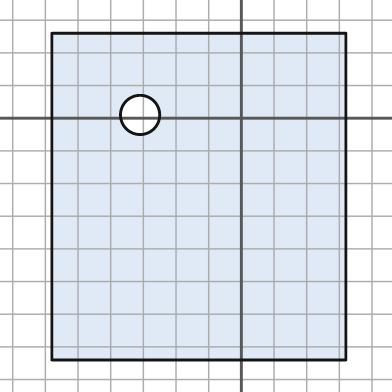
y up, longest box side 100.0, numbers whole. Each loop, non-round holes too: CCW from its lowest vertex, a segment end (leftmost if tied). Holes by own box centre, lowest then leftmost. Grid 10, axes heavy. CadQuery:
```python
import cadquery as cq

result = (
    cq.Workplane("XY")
    .moveTo(-58.0, -74.0)
    .lineTo(32.0, -74.0)
    .lineTo(32.0, 26.0)
    .lineTo(-58.0, 26.0)
    .close()
    .moveTo(-31.0, 1.0)
    .circle(6.0)
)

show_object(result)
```